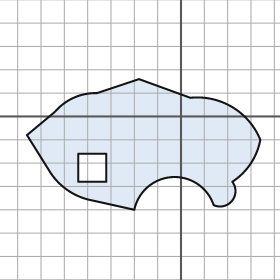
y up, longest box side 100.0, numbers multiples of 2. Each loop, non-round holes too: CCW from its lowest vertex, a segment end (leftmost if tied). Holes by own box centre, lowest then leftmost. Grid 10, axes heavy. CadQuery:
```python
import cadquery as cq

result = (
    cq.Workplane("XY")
    .moveTo(-20.0, -40.0)
    .threePointArc((-4.0, -26.0), (14.0, -38.0))
    .threePointArc((22.0, -36.0), (22.0, -28.0))
    .threePointArc((30.0, -20.0), (34.0, -10.0))
    .threePointArc((22.0, 4.0), (4.0, 8.0))
    .lineTo(-18.0, 16.0)
    .lineTo(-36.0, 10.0)
    .threePointArc((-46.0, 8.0), (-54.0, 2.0))
    .lineTo(-66.0, -8.0)
    .lineTo(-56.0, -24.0)
    .threePointArc((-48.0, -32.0), (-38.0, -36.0))
    .close()
    .moveTo(-44.0, -28.0)
    .lineTo(-32.0, -28.0)
    .lineTo(-32.0, -16.0)
    .lineTo(-44.0, -16.0)
    .close()
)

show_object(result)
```